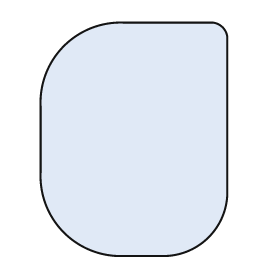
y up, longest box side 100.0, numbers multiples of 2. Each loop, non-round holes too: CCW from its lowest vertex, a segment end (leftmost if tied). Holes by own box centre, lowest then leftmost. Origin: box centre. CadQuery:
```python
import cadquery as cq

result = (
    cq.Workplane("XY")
    .moveTo(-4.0, -50.0)
    .lineTo(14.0, -50.0)
    .threePointArc((32.0, -42.0), (40.0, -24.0))
    .lineTo(40.0, 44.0)
    .threePointArc((38.0, 48.0), (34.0, 50.0))
    .lineTo(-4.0, 50.0)
    .threePointArc((-30.0, 40.0), (-40.0, 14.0))
    .lineTo(-40.0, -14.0)
    .threePointArc((-30.0, -40.0), (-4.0, -50.0))
    .close()
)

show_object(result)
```